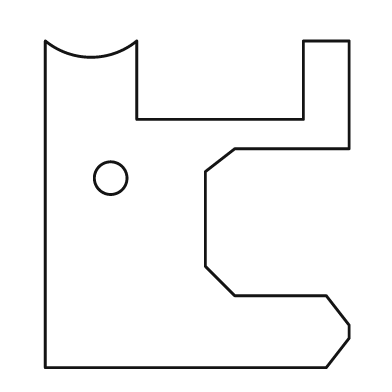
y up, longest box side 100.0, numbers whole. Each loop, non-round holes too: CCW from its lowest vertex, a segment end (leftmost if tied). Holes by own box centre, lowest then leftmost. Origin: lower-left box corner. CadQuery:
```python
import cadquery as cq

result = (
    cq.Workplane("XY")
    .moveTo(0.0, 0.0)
    .lineTo(86.0, 0.0)
    .lineTo(93.0, 9.0)
    .lineTo(93.0, 13.0)
    .lineTo(86.0, 22.0)
    .lineTo(58.0, 22.0)
    .lineTo(49.0, 31.0)
    .lineTo(49.0, 60.0)
    .lineTo(58.0, 67.0)
    .lineTo(93.0, 67.0)
    .lineTo(93.0, 100.0)
    .lineTo(79.0, 100.0)
    .lineTo(79.0, 76.0)
    .lineTo(28.0, 76.0)
    .lineTo(28.0, 100.0)
    .threePointArc((14.0, 95.0), (0.0, 100.0))
    .close()
    .moveTo(20.0, 58.0)
    .circle(5.0)
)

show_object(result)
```